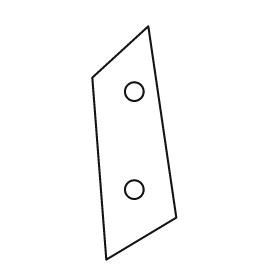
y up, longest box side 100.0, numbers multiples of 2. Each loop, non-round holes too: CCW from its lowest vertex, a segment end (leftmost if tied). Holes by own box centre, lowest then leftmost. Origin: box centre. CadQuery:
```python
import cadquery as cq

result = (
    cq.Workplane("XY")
    .moveTo(-12.0, -50.0)
    .lineTo(18.0, -32.0)
    .lineTo(6.0, 50.0)
    .lineTo(-18.0, 28.0)
    .close()
    .moveTo(0.0, -20.0)
    .circle(4.0)
    .moveTo(0.0, 22.0)
    .circle(4.0)
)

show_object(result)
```